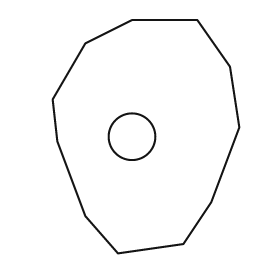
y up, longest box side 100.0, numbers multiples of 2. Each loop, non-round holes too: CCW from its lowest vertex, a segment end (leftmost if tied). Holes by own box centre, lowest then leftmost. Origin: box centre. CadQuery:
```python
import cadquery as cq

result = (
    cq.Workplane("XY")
    .moveTo(-12.0, -50.0)
    .lineTo(16.0, -46.0)
    .lineTo(28.0, -28.0)
    .lineTo(40.0, 4.0)
    .lineTo(36.0, 30.0)
    .lineTo(22.0, 50.0)
    .lineTo(-6.0, 50.0)
    .lineTo(-26.0, 40.0)
    .lineTo(-40.0, 16.0)
    .lineTo(-38.0, -2.0)
    .lineTo(-26.0, -34.0)
    .close()
    .moveTo(-6.0, 0.0)
    .circle(10.0)
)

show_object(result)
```